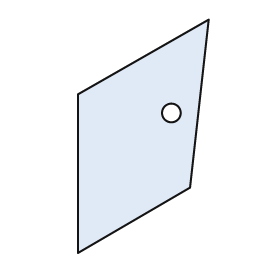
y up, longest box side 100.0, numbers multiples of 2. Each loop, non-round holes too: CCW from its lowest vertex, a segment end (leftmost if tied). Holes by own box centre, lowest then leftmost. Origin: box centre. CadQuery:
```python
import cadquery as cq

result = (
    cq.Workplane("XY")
    .moveTo(-28.0, -50.0)
    .lineTo(20.0, -22.0)
    .lineTo(28.0, 50.0)
    .lineTo(-28.0, 18.0)
    .close()
    .moveTo(12.0, 10.0)
    .circle(4.0)
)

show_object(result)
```